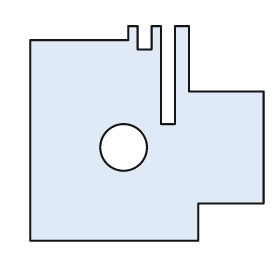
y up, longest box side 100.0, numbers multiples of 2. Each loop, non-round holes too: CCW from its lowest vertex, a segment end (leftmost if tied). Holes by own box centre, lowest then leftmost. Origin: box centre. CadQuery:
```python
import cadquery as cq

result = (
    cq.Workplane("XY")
    .moveTo(-50.0, -46.0)
    .lineTo(22.0, -46.0)
    .lineTo(22.0, -30.0)
    .lineTo(50.0, -30.0)
    .lineTo(50.0, 18.0)
    .lineTo(18.0, 18.0)
    .lineTo(18.0, 46.0)
    .lineTo(12.0, 46.0)
    .lineTo(12.0, 4.0)
    .lineTo(6.0, 4.0)
    .lineTo(6.0, 46.0)
    .lineTo(2.0, 46.0)
    .lineTo(2.0, 36.0)
    .lineTo(-4.0, 36.0)
    .lineTo(-4.0, 46.0)
    .lineTo(-8.0, 46.0)
    .lineTo(-8.0, 40.0)
    .lineTo(-50.0, 40.0)
    .close()
    .moveTo(-10.0, -6.0)
    .circle(10.0)
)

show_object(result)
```